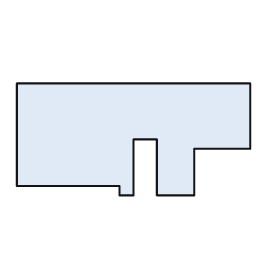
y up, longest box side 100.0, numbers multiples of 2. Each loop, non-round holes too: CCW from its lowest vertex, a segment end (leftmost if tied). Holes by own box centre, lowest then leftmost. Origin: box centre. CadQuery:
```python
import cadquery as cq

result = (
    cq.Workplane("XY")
    .moveTo(-6.0, -24.0)
    .lineTo(0.0, -24.0)
    .lineTo(0.0, 0.0)
    .lineTo(10.0, 0.0)
    .lineTo(10.0, -24.0)
    .lineTo(26.0, -24.0)
    .lineTo(26.0, -4.0)
    .lineTo(50.0, -4.0)
    .lineTo(50.0, 24.0)
    .lineTo(-50.0, 24.0)
    .lineTo(-50.0, -20.0)
    .lineTo(-6.0, -20.0)
    .close()
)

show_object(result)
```